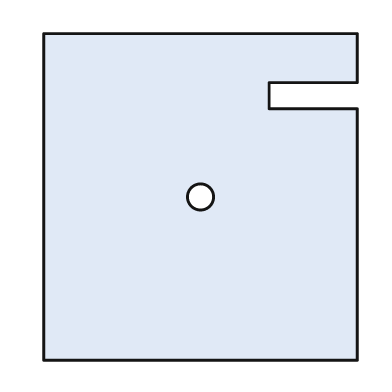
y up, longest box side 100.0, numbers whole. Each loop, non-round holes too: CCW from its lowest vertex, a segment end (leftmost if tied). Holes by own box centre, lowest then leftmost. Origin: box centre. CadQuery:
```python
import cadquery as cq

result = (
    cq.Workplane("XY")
    .moveTo(-48.0, -50.0)
    .lineTo(48.0, -50.0)
    .lineTo(48.0, 27.0)
    .lineTo(21.0, 27.0)
    .lineTo(21.0, 35.0)
    .lineTo(48.0, 35.0)
    .lineTo(48.0, 50.0)
    .lineTo(-48.0, 50.0)
    .close()
    .moveTo(0.0, 0.0)
    .circle(4.0)
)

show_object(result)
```